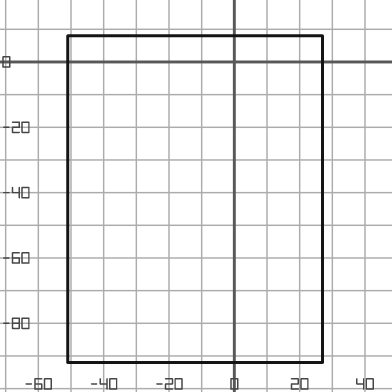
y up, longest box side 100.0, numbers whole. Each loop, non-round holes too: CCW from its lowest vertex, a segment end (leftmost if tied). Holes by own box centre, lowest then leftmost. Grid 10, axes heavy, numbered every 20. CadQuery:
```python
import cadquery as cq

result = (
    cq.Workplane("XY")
    .moveTo(-51.0, -92.0)
    .lineTo(27.0, -92.0)
    .lineTo(27.0, 8.0)
    .lineTo(-51.0, 8.0)
    .close()
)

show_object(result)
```